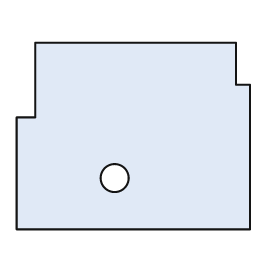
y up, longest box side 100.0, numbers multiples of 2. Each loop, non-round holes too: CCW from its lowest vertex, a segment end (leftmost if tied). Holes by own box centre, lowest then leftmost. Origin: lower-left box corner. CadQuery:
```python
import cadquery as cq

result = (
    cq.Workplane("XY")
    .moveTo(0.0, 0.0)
    .lineTo(100.0, 0.0)
    .lineTo(100.0, 62.0)
    .lineTo(94.0, 62.0)
    .lineTo(94.0, 80.0)
    .lineTo(8.0, 80.0)
    .lineTo(8.0, 48.0)
    .lineTo(0.0, 48.0)
    .close()
    .moveTo(42.0, 22.0)
    .circle(6.0)
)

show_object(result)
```